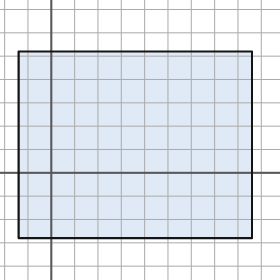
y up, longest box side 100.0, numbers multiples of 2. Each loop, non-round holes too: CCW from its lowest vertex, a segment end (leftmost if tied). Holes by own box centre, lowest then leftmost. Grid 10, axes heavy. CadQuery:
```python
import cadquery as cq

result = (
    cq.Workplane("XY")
    .moveTo(-14.0, -28.0)
    .lineTo(86.0, -28.0)
    .lineTo(86.0, 52.0)
    .lineTo(-14.0, 52.0)
    .close()
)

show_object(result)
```